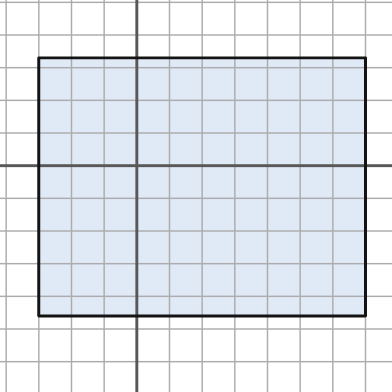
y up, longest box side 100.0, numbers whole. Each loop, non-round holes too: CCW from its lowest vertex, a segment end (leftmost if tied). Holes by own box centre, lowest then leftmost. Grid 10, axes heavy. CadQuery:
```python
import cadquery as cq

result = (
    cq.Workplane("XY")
    .moveTo(-30.0, -46.0)
    .lineTo(70.0, -46.0)
    .lineTo(70.0, 33.0)
    .lineTo(-30.0, 33.0)
    .close()
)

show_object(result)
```